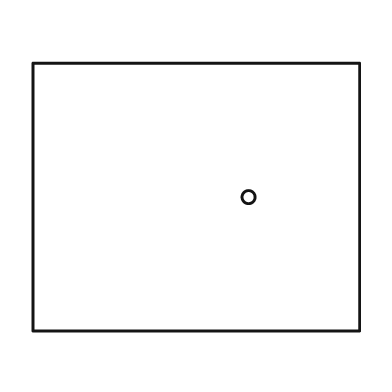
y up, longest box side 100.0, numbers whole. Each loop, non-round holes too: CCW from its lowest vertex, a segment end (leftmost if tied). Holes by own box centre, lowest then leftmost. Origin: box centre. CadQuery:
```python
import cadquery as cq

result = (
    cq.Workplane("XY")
    .moveTo(-50.0, -41.0)
    .lineTo(50.0, -41.0)
    .lineTo(50.0, 41.0)
    .lineTo(-50.0, 41.0)
    .close()
    .moveTo(16.0, 0.0)
    .circle(2.0)
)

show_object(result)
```